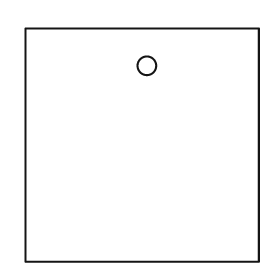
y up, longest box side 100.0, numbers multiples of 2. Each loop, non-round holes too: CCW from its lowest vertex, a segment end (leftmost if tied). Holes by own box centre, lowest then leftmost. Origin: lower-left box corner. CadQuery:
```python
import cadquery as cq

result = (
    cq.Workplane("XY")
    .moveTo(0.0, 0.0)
    .lineTo(100.0, 0.0)
    .lineTo(100.0, 100.0)
    .lineTo(0.0, 100.0)
    .close()
    .moveTo(52.0, 84.0)
    .circle(4.0)
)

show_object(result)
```